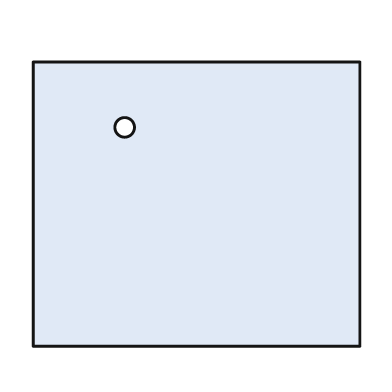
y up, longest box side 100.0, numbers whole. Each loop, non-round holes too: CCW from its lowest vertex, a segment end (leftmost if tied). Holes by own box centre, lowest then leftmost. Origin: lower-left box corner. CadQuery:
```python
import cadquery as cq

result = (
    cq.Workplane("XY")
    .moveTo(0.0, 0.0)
    .lineTo(100.0, 0.0)
    .lineTo(100.0, 87.0)
    .lineTo(0.0, 87.0)
    .close()
    .moveTo(28.0, 67.0)
    .circle(3.0)
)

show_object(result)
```